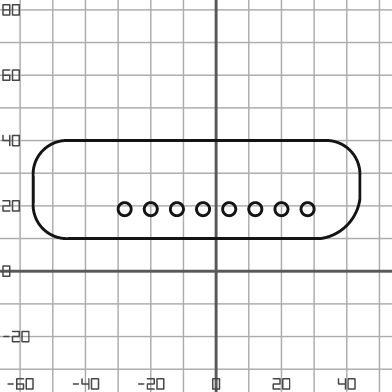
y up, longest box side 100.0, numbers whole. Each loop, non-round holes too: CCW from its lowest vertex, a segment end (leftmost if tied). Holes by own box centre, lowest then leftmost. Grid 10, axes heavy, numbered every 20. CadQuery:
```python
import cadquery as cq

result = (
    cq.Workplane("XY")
    .moveTo(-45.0, 10.0)
    .lineTo(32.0, 10.0)
    .threePointArc((40.0, 14.0), (44.0, 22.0))
    .lineTo(44.0, 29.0)
    .threePointArc((41.0, 37.0), (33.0, 40.0))
    .lineTo(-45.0, 40.0)
    .threePointArc((-53.0, 37.0), (-56.0, 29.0))
    .lineTo(-56.0, 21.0)
    .threePointArc((-53.0, 13.0), (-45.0, 10.0))
    .close()
    .moveTo(-28.0, 19.0)
    .circle(2.0)
    .moveTo(-20.0, 19.0)
    .circle(2.0)
    .moveTo(-12.0, 19.0)
    .circle(2.0)
    .moveTo(-4.0, 19.0)
    .circle(2.0)
    .moveTo(4.0, 19.0)
    .circle(2.0)
    .moveTo(12.0, 19.0)
    .circle(2.0)
    .moveTo(20.0, 19.0)
    .circle(2.0)
    .moveTo(28.0, 19.0)
    .circle(2.0)
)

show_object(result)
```